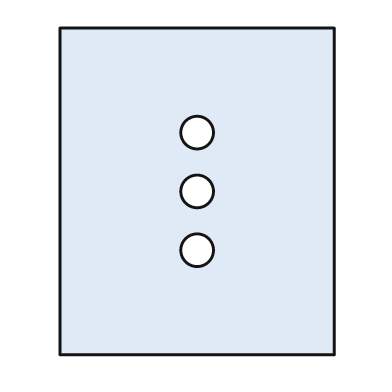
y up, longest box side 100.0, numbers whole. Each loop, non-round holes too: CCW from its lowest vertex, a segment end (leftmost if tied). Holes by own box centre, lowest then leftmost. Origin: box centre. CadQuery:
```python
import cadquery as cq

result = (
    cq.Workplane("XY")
    .moveTo(-42.0, -50.0)
    .lineTo(42.0, -50.0)
    .lineTo(42.0, 50.0)
    .lineTo(-42.0, 50.0)
    .close()
    .moveTo(0.0, -18.0)
    .circle(5.0)
    .moveTo(0.0, 0.0)
    .circle(5.0)
    .moveTo(0.0, 18.0)
    .circle(5.0)
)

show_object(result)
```